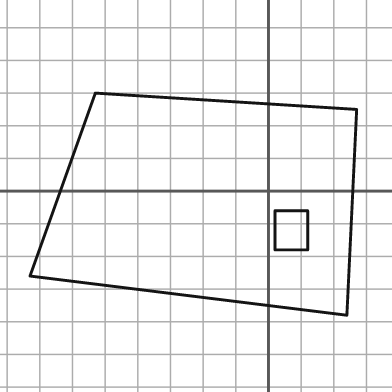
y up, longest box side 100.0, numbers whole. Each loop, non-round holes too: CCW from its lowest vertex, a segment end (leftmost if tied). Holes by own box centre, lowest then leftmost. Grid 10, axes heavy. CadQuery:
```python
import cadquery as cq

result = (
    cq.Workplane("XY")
    .moveTo(24.0, -38.0)
    .lineTo(27.0, 25.0)
    .lineTo(-53.0, 30.0)
    .lineTo(-73.0, -26.0)
    .close()
    .moveTo(2.0, -18.0)
    .lineTo(12.0, -18.0)
    .lineTo(12.0, -6.0)
    .lineTo(2.0, -6.0)
    .close()
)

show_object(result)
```